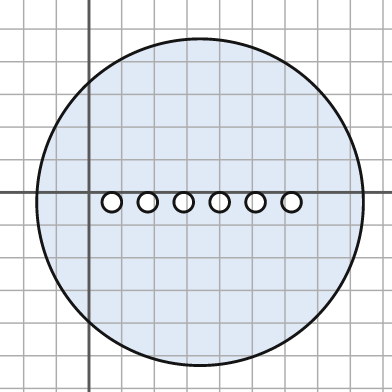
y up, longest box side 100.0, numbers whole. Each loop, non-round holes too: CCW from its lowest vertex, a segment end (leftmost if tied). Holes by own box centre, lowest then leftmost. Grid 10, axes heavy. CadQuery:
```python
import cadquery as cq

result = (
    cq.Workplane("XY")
    .moveTo(34.0, -3.0)
    .circle(50.0)
    .moveTo(7.0, -3.0)
    .circle(3.0)
    .moveTo(18.0, -3.0)
    .circle(3.0)
    .moveTo(29.0, -3.0)
    .circle(3.0)
    .moveTo(40.0, -3.0)
    .circle(3.0)
    .moveTo(51.0, -3.0)
    .circle(3.0)
    .moveTo(62.0, -3.0)
    .circle(3.0)
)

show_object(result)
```